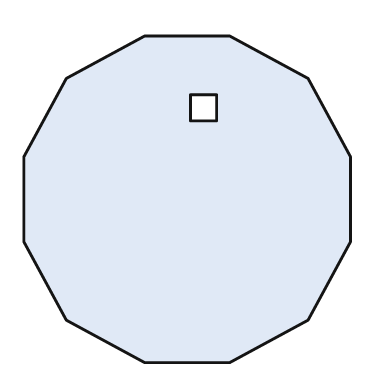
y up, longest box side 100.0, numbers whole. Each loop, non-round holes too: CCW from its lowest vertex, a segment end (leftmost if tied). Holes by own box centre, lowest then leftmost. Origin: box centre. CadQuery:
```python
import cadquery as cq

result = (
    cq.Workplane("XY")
    .moveTo(-13.0, -50.0)
    .lineTo(13.0, -50.0)
    .lineTo(37.0, -37.0)
    .lineTo(50.0, -13.0)
    .lineTo(50.0, 13.0)
    .lineTo(37.0, 37.0)
    .lineTo(13.0, 50.0)
    .lineTo(-13.0, 50.0)
    .lineTo(-37.0, 37.0)
    .lineTo(-50.0, 13.0)
    .lineTo(-50.0, -13.0)
    .lineTo(-37.0, -37.0)
    .close()
    .moveTo(1.0, 24.0)
    .lineTo(9.0, 24.0)
    .lineTo(9.0, 32.0)
    .lineTo(1.0, 32.0)
    .close()
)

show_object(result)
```